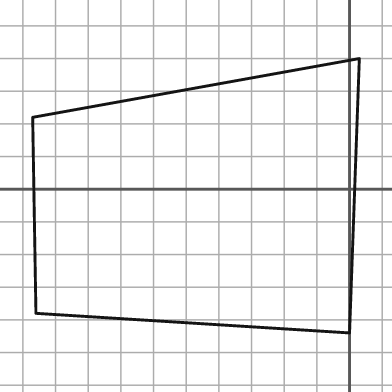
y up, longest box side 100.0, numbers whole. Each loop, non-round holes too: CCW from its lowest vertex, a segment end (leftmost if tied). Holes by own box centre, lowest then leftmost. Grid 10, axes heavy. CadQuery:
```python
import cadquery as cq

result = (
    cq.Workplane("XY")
    .moveTo(0.0, -44.0)
    .lineTo(3.0, 40.0)
    .lineTo(-97.0, 22.0)
    .lineTo(-96.0, -38.0)
    .close()
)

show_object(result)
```